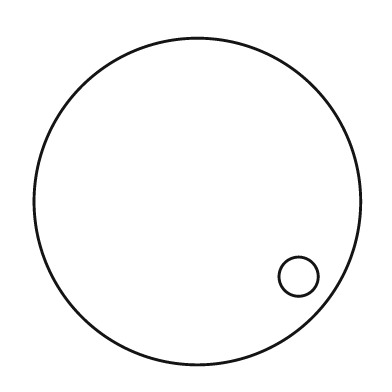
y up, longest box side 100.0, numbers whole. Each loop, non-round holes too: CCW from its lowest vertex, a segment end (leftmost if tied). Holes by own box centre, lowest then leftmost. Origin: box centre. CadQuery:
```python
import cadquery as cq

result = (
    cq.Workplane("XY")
    .moveTo(0.0, 0.0)
    .circle(50.0)
    .moveTo(31.0, -23.0)
    .circle(6.0)
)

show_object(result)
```